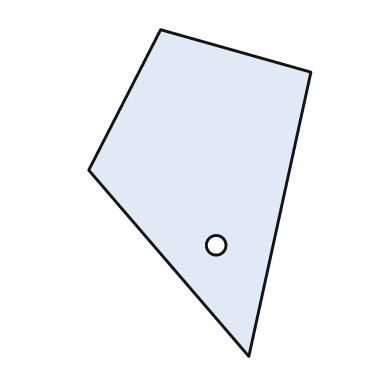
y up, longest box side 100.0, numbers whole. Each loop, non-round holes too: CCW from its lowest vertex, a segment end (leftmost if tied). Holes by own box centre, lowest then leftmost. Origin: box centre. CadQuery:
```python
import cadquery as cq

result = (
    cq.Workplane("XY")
    .moveTo(15.0, -50.0)
    .lineTo(34.0, 37.0)
    .lineTo(-12.0, 50.0)
    .lineTo(-34.0, 7.0)
    .close()
    .moveTo(5.0, -16.0)
    .circle(3.0)
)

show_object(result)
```